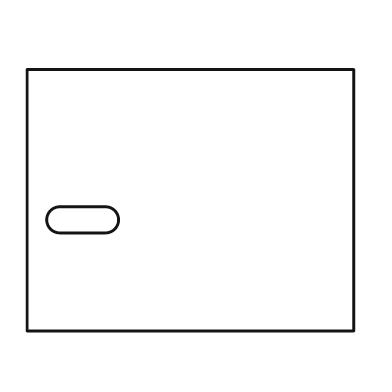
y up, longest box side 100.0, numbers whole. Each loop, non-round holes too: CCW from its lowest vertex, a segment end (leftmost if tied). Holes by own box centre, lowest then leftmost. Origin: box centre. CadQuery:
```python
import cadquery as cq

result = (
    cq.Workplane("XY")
    .moveTo(-50.0, -40.0)
    .lineTo(50.0, -40.0)
    .lineTo(50.0, 40.0)
    .lineTo(-50.0, 40.0)
    .close()
    .moveTo(-40.0, -10.0)
    .lineTo(-26.0, -10.0)
    .threePointArc((-22.0, -6.0), (-26.0, -2.0))
    .lineTo(-40.0, -2.0)
    .threePointArc((-44.0, -6.0), (-40.0, -10.0))
    .close()
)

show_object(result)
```